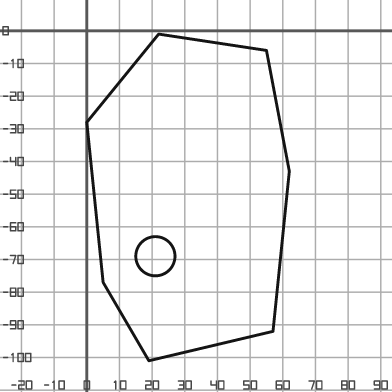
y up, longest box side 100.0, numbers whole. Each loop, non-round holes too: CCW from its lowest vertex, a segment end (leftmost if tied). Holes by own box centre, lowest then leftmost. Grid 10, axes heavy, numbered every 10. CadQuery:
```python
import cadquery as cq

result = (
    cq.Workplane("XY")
    .moveTo(19.0, -101.0)
    .lineTo(57.0, -92.0)
    .lineTo(62.0, -43.0)
    .lineTo(55.0, -6.0)
    .lineTo(22.0, -1.0)
    .lineTo(0.0, -28.0)
    .lineTo(5.0, -77.0)
    .close()
    .moveTo(21.0, -69.0)
    .circle(6.0)
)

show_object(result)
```